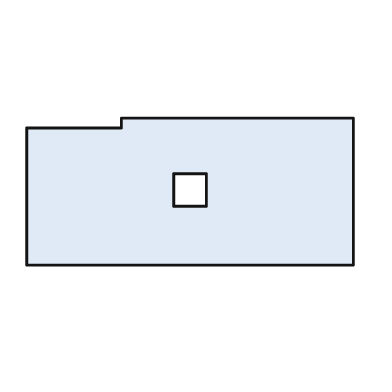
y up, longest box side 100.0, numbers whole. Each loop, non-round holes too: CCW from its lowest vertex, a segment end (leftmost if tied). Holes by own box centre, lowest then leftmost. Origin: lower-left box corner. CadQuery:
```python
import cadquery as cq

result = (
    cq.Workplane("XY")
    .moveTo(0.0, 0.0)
    .lineTo(100.0, 0.0)
    .lineTo(100.0, 45.0)
    .lineTo(29.0, 45.0)
    .lineTo(29.0, 42.0)
    .lineTo(0.0, 42.0)
    .close()
    .moveTo(45.0, 18.0)
    .lineTo(55.0, 18.0)
    .lineTo(55.0, 28.0)
    .lineTo(45.0, 28.0)
    .close()
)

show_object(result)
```